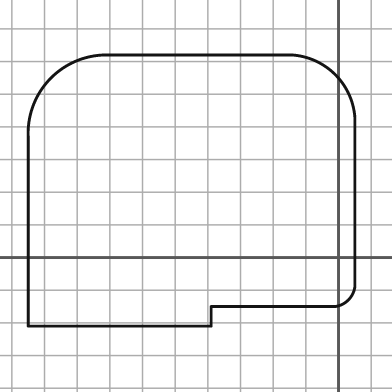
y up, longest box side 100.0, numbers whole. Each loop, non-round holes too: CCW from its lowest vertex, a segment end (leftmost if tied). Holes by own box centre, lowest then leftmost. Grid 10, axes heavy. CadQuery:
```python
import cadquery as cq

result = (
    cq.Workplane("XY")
    .moveTo(-95.0, -21.0)
    .lineTo(-39.0, -21.0)
    .lineTo(-39.0, -15.0)
    .lineTo(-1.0, -15.0)
    .threePointArc((3.0, -13.0), (5.0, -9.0))
    .lineTo(5.0, 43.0)
    .threePointArc((-1.0, 56.0), (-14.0, 62.0))
    .lineTo(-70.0, 62.0)
    .threePointArc((-88.0, 55.0), (-95.0, 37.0))
    .close()
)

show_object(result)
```